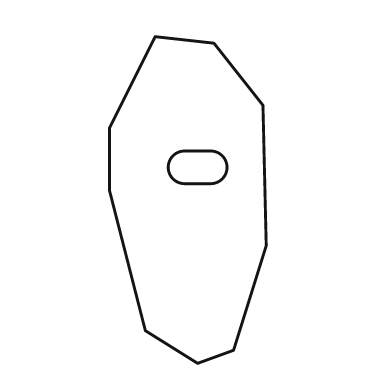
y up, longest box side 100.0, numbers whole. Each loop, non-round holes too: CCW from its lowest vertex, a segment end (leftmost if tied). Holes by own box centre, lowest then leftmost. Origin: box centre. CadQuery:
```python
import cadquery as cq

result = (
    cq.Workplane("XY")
    .moveTo(3.0, -50.0)
    .lineTo(14.0, -46.0)
    .lineTo(24.0, -14.0)
    .lineTo(23.0, 29.0)
    .lineTo(8.0, 48.0)
    .lineTo(-10.0, 50.0)
    .lineTo(-24.0, 22.0)
    .lineTo(-24.0, 3.0)
    .lineTo(-13.0, -40.0)
    .close()
    .moveTo(-1.0, 5.0)
    .lineTo(7.0, 5.0)
    .threePointArc((12.0, 10.0), (7.0, 15.0))
    .lineTo(-1.0, 15.0)
    .threePointArc((-6.0, 10.0), (-1.0, 5.0))
    .close()
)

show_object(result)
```